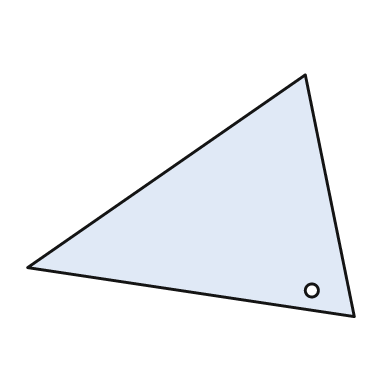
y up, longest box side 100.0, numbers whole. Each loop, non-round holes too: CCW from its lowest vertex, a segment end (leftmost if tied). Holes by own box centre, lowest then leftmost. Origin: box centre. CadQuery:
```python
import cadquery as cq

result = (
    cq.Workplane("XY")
    .moveTo(50.0, -37.0)
    .lineTo(35.0, 37.0)
    .lineTo(-50.0, -22.0)
    .close()
    .moveTo(37.0, -29.0)
    .circle(2.0)
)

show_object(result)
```